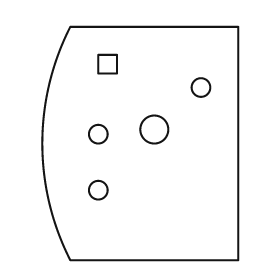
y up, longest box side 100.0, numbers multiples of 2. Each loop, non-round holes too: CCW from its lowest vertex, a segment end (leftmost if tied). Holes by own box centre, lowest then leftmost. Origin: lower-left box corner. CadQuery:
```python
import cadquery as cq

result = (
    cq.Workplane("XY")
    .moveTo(12.0, 0.0)
    .lineTo(84.0, 0.0)
    .lineTo(84.0, 100.0)
    .lineTo(12.0, 100.0)
    .threePointArc((0.0, 50.0), (12.0, 0.0))
    .close()
    .moveTo(24.0, 30.0)
    .circle(4.0)
    .moveTo(24.0, 54.0)
    .circle(4.0)
    .moveTo(48.0, 56.0)
    .circle(6.0)
    .moveTo(68.0, 74.0)
    .circle(4.0)
    .moveTo(24.0, 80.0)
    .lineTo(32.0, 80.0)
    .lineTo(32.0, 88.0)
    .lineTo(24.0, 88.0)
    .close()
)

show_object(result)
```